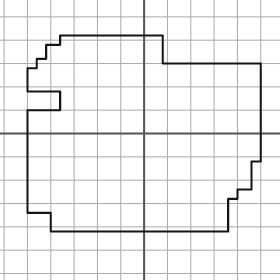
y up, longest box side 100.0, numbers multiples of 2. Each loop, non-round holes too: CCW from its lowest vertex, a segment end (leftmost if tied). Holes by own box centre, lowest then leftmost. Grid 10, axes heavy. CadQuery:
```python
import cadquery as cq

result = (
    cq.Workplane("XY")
    .moveTo(-40.0, -42.0)
    .lineTo(36.0, -42.0)
    .lineTo(36.0, -28.0)
    .lineTo(40.0, -28.0)
    .lineTo(40.0, -24.0)
    .lineTo(46.0, -24.0)
    .lineTo(46.0, -12.0)
    .lineTo(50.0, -12.0)
    .lineTo(50.0, 30.0)
    .lineTo(8.0, 30.0)
    .lineTo(8.0, 42.0)
    .lineTo(-36.0, 42.0)
    .lineTo(-36.0, 38.0)
    .lineTo(-42.0, 38.0)
    .lineTo(-42.0, 32.0)
    .lineTo(-46.0, 32.0)
    .lineTo(-46.0, 28.0)
    .lineTo(-50.0, 28.0)
    .lineTo(-50.0, 18.0)
    .lineTo(-36.0, 18.0)
    .lineTo(-36.0, 10.0)
    .lineTo(-50.0, 10.0)
    .lineTo(-50.0, -34.0)
    .lineTo(-40.0, -34.0)
    .close()
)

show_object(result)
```